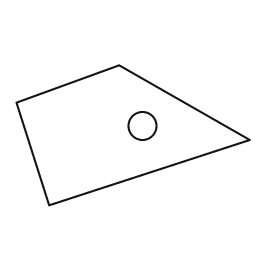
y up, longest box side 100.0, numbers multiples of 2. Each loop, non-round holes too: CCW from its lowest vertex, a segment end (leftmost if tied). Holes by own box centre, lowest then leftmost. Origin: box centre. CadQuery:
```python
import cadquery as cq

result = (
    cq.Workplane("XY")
    .moveTo(-36.0, -30.0)
    .lineTo(50.0, -2.0)
    .lineTo(-6.0, 30.0)
    .lineTo(-50.0, 14.0)
    .close()
    .moveTo(4.0, 4.0)
    .circle(6.0)
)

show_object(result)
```